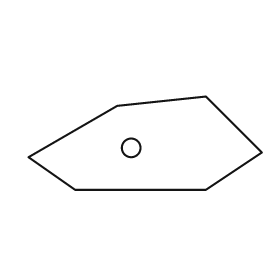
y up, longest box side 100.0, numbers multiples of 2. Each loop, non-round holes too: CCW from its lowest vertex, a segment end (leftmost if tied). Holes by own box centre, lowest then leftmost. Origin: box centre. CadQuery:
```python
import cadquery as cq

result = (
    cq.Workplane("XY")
    .moveTo(-30.0, -20.0)
    .lineTo(26.0, -20.0)
    .lineTo(50.0, -4.0)
    .lineTo(26.0, 20.0)
    .lineTo(-12.0, 16.0)
    .lineTo(-50.0, -6.0)
    .close()
    .moveTo(-6.0, -2.0)
    .circle(4.0)
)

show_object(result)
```